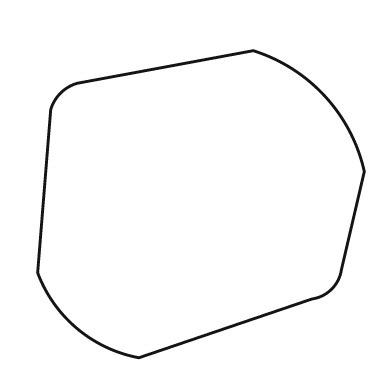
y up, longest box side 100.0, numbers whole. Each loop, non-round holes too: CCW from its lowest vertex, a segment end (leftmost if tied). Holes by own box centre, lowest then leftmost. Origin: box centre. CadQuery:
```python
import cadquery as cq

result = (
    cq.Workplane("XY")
    .moveTo(-19.0, -47.0)
    .lineTo(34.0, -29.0)
    .threePointArc((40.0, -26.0), (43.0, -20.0))
    .lineTo(50.0, 10.0)
    .threePointArc((38.0, 33.0), (16.0, 47.0))
    .lineTo(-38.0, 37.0)
    .threePointArc((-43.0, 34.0), (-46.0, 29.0))
    .lineTo(-50.0, -21.0)
    .threePointArc((-38.0, -38.0), (-19.0, -47.0))
    .close()
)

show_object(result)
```